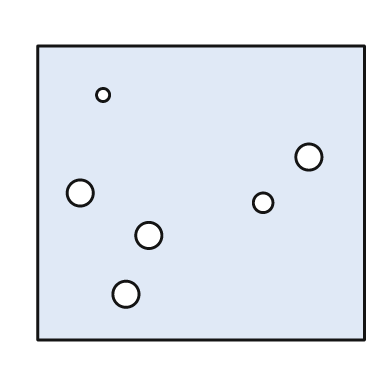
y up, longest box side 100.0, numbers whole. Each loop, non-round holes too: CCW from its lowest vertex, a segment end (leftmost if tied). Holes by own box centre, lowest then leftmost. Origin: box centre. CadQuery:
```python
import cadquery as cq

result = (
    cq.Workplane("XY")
    .moveTo(-50.0, -45.0)
    .lineTo(50.0, -45.0)
    .lineTo(50.0, 45.0)
    .lineTo(-50.0, 45.0)
    .close()
    .moveTo(-23.0, -31.0)
    .circle(4.0)
    .moveTo(-16.0, -13.0)
    .circle(4.0)
    .moveTo(19.0, -3.0)
    .circle(3.0)
    .moveTo(-37.0, 0.0)
    .circle(4.0)
    .moveTo(33.0, 11.0)
    .circle(4.0)
    .moveTo(-30.0, 30.0)
    .circle(2.0)
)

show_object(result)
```